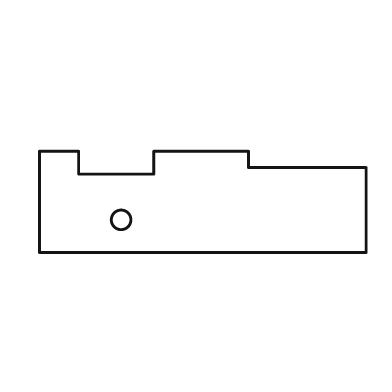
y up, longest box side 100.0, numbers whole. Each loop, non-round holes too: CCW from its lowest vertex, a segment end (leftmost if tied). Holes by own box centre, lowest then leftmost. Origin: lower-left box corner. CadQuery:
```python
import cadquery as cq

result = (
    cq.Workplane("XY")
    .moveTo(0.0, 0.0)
    .lineTo(100.0, 0.0)
    .lineTo(100.0, 26.0)
    .lineTo(64.0, 26.0)
    .lineTo(64.0, 31.0)
    .lineTo(35.0, 31.0)
    .lineTo(35.0, 24.0)
    .lineTo(12.0, 24.0)
    .lineTo(12.0, 31.0)
    .lineTo(0.0, 31.0)
    .close()
    .moveTo(25.0, 10.0)
    .circle(3.0)
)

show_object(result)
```